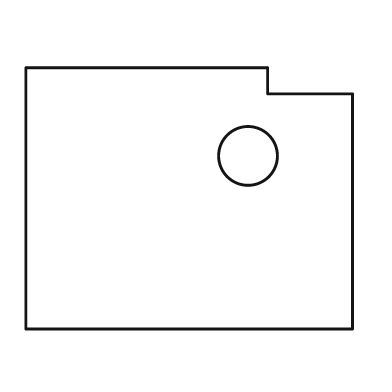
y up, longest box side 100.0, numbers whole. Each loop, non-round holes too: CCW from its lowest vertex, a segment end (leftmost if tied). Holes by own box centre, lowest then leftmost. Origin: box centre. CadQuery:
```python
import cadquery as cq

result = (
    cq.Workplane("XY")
    .moveTo(-50.0, -40.0)
    .lineTo(50.0, -40.0)
    .lineTo(50.0, 32.0)
    .lineTo(24.0, 32.0)
    .lineTo(24.0, 40.0)
    .lineTo(-50.0, 40.0)
    .close()
    .moveTo(18.0, 13.0)
    .circle(9.0)
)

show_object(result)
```